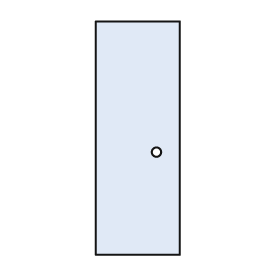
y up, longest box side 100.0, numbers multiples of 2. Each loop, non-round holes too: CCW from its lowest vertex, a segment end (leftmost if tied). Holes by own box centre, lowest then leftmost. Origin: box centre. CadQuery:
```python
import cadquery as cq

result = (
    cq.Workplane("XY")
    .moveTo(-18.0, -50.0)
    .lineTo(18.0, -50.0)
    .lineTo(18.0, 50.0)
    .lineTo(-18.0, 50.0)
    .close()
    .moveTo(8.0, -6.0)
    .circle(2.0)
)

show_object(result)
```